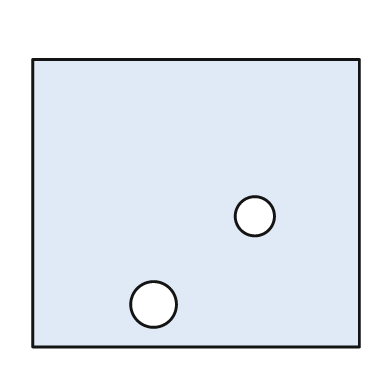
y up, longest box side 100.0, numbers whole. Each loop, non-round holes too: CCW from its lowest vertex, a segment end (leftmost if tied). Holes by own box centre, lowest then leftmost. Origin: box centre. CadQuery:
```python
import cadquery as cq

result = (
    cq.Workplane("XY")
    .moveTo(-50.0, -44.0)
    .lineTo(50.0, -44.0)
    .lineTo(50.0, 44.0)
    .lineTo(-50.0, 44.0)
    .close()
    .moveTo(-13.0, -31.0)
    .circle(7.0)
    .moveTo(18.0, -4.0)
    .circle(6.0)
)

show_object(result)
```